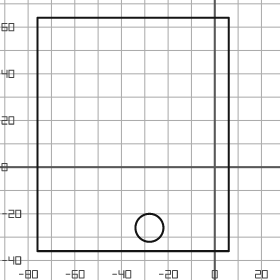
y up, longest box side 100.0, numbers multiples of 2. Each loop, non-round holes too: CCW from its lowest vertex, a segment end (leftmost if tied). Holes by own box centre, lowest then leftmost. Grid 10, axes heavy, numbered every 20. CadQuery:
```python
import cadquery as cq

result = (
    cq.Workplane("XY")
    .moveTo(-76.0, -36.0)
    .lineTo(6.0, -36.0)
    .lineTo(6.0, 64.0)
    .lineTo(-76.0, 64.0)
    .close()
    .moveTo(-28.0, -26.0)
    .circle(6.0)
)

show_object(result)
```